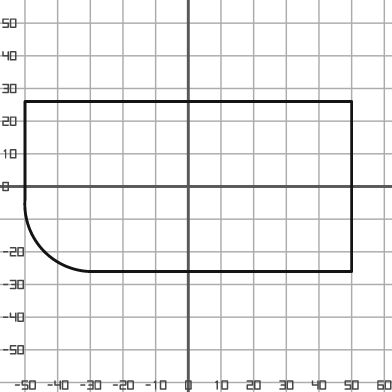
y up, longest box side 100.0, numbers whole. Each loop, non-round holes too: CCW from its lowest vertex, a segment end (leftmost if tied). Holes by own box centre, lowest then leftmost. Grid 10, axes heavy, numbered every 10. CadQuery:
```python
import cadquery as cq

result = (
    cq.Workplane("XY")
    .moveTo(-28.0, -26.0)
    .lineTo(50.0, -26.0)
    .lineTo(50.0, 26.0)
    .lineTo(-50.0, 26.0)
    .lineTo(-50.0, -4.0)
    .threePointArc((-44.0, -20.0), (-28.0, -26.0))
    .close()
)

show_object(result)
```